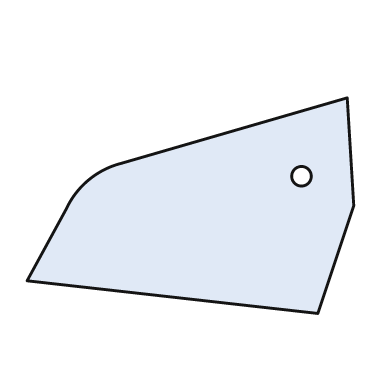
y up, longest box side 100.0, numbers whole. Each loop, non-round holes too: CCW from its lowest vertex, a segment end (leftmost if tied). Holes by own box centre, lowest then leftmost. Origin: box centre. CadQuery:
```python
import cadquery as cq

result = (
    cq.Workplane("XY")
    .moveTo(39.0, -33.0)
    .lineTo(50.0, 0.0)
    .lineTo(48.0, 33.0)
    .lineTo(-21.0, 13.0)
    .threePointArc((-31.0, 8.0), (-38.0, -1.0))
    .lineTo(-50.0, -23.0)
    .close()
    .moveTo(34.0, 9.0)
    .circle(3.0)
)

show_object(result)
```